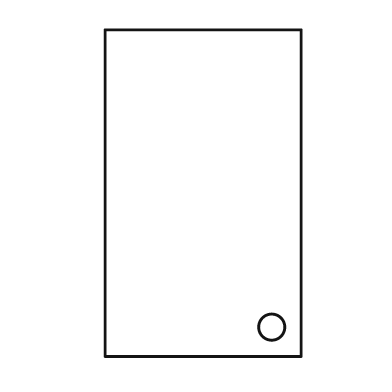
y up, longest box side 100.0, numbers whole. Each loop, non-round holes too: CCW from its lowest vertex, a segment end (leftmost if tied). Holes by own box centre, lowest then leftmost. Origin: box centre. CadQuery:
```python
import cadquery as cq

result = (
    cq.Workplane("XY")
    .moveTo(-30.0, -50.0)
    .lineTo(30.0, -50.0)
    .lineTo(30.0, 50.0)
    .lineTo(-30.0, 50.0)
    .close()
    .moveTo(21.0, -41.0)
    .circle(4.0)
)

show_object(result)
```